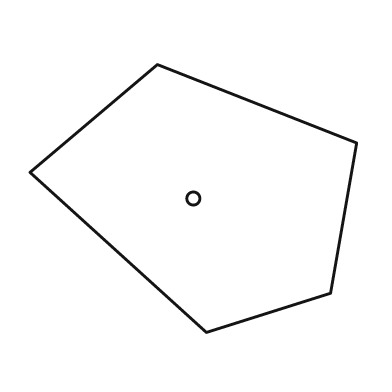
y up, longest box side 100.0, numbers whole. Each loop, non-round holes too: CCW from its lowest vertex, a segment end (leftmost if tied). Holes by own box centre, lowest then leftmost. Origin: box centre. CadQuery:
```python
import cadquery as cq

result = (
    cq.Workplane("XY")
    .moveTo(4.0, -41.0)
    .lineTo(42.0, -29.0)
    .lineTo(50.0, 17.0)
    .lineTo(-11.0, 41.0)
    .lineTo(-50.0, 8.0)
    .close()
    .moveTo(0.0, 0.0)
    .circle(2.0)
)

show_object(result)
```